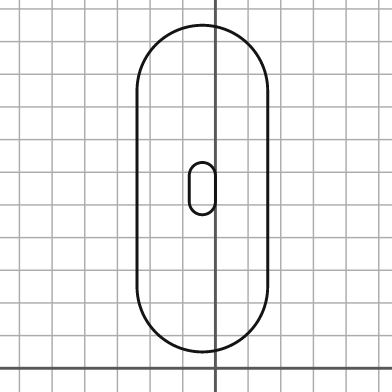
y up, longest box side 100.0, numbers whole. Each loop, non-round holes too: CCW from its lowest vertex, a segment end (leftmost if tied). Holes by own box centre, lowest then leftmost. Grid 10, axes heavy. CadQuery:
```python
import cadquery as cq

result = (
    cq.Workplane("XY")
    .moveTo(-24.0, 25.0)
    .threePointArc((-4.0, 5.0), (16.0, 25.0))
    .lineTo(16.0, 85.0)
    .threePointArc((-4.0, 105.0), (-24.0, 85.0))
    .close()
    .moveTo(-8.0, 51.0)
    .threePointArc((-4.0, 47.0), (0.0, 51.0))
    .lineTo(0.0, 59.0)
    .threePointArc((-4.0, 63.0), (-8.0, 59.0))
    .close()
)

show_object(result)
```